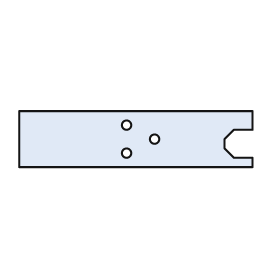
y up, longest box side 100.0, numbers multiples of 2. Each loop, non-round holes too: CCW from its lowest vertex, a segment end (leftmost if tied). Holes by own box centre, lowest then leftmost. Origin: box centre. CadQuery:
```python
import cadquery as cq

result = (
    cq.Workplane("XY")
    .moveTo(-50.0, -12.0)
    .lineTo(50.0, -12.0)
    .lineTo(50.0, -8.0)
    .lineTo(42.0, -8.0)
    .lineTo(38.0, -4.0)
    .lineTo(38.0, 0.0)
    .lineTo(42.0, 4.0)
    .lineTo(50.0, 4.0)
    .lineTo(50.0, 12.0)
    .lineTo(-50.0, 12.0)
    .close()
    .moveTo(-4.0, -6.0)
    .circle(2.0)
    .moveTo(8.0, 0.0)
    .circle(2.0)
    .moveTo(-4.0, 6.0)
    .circle(2.0)
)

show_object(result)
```